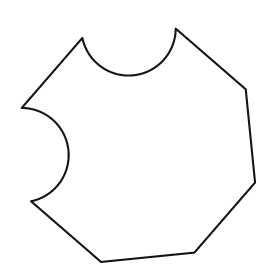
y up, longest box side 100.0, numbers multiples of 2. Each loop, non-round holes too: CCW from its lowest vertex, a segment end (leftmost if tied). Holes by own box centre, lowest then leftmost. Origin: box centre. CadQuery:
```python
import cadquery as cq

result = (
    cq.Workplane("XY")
    .moveTo(-16.0, -50.0)
    .lineTo(24.0, -46.0)
    .lineTo(50.0, -16.0)
    .lineTo(46.0, 24.0)
    .lineTo(16.0, 50.0)
    .threePointArc((-2.0, 30.0), (-24.0, 46.0))
    .lineTo(-50.0, 16.0)
    .threePointArc((-30.0, -2.0), (-46.0, -24.0))
    .close()
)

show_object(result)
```